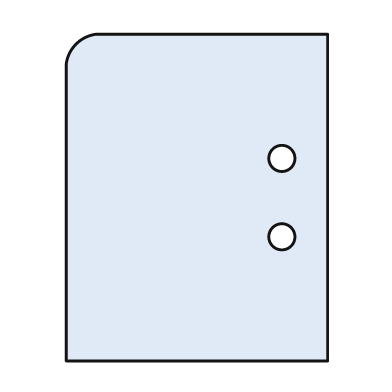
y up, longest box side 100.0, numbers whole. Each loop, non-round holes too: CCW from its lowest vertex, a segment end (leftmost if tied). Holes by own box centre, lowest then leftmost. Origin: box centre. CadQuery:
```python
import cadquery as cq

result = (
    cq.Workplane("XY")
    .moveTo(-40.0, -50.0)
    .lineTo(40.0, -50.0)
    .lineTo(40.0, 50.0)
    .lineTo(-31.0, 50.0)
    .threePointArc((-37.0, 47.0), (-40.0, 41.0))
    .close()
    .moveTo(26.0, -12.0)
    .circle(4.0)
    .moveTo(26.0, 12.0)
    .circle(4.0)
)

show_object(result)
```